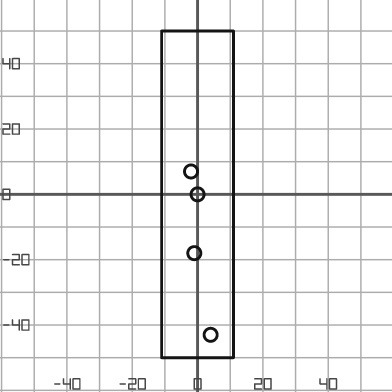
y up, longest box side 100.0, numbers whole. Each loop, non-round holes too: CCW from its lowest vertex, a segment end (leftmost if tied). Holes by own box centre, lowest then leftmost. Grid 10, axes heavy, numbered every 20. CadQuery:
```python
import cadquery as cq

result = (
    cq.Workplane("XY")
    .moveTo(-11.0, -50.0)
    .lineTo(11.0, -50.0)
    .lineTo(11.0, 50.0)
    .lineTo(-11.0, 50.0)
    .close()
    .moveTo(4.0, -43.0)
    .circle(2.0)
    .moveTo(-1.0, -18.0)
    .circle(2.0)
    .moveTo(0.0, 0.0)
    .circle(2.0)
    .moveTo(-2.0, 7.0)
    .circle(2.0)
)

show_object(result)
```